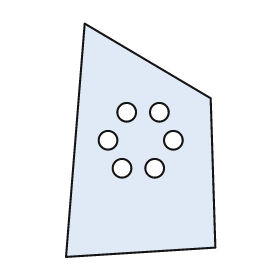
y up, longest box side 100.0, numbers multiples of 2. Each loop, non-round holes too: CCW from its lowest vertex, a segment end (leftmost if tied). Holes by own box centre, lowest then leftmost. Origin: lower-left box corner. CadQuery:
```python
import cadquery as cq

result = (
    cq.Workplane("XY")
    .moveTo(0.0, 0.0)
    .lineTo(64.0, 4.0)
    .lineTo(62.0, 68.0)
    .lineTo(8.0, 100.0)
    .close()
    .moveTo(24.0, 38.0)
    .circle(4.0)
    .moveTo(38.0, 38.0)
    .circle(4.0)
    .moveTo(18.0, 50.0)
    .circle(4.0)
    .moveTo(46.0, 50.0)
    .circle(4.0)
    .moveTo(26.0, 62.0)
    .circle(4.0)
    .moveTo(40.0, 62.0)
    .circle(4.0)
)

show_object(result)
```